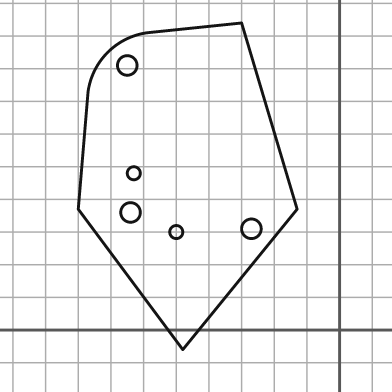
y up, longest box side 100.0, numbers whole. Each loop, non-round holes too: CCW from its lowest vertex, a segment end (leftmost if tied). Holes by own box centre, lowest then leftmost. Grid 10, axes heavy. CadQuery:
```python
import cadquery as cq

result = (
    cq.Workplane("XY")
    .moveTo(-48.0, -6.0)
    .lineTo(-13.0, 37.0)
    .lineTo(-30.0, 94.0)
    .lineTo(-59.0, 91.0)
    .threePointArc((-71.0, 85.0), (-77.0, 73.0))
    .lineTo(-80.0, 37.0)
    .close()
    .moveTo(-50.0, 30.0)
    .circle(2.0)
    .moveTo(-27.0, 31.0)
    .circle(3.0)
    .moveTo(-64.0, 36.0)
    .circle(3.0)
    .moveTo(-63.0, 48.0)
    .circle(2.0)
    .moveTo(-65.0, 81.0)
    .circle(3.0)
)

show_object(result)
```